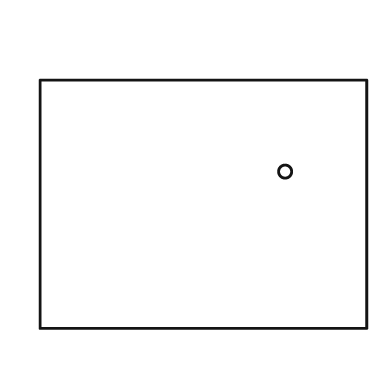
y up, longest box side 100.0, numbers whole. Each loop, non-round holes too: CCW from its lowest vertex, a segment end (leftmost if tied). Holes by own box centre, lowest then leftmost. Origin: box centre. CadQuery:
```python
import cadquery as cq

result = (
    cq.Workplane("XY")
    .moveTo(-50.0, -38.0)
    .lineTo(50.0, -38.0)
    .lineTo(50.0, 38.0)
    .lineTo(-50.0, 38.0)
    .close()
    .moveTo(25.0, 10.0)
    .circle(2.0)
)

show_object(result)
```